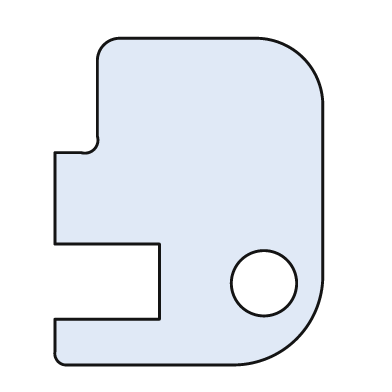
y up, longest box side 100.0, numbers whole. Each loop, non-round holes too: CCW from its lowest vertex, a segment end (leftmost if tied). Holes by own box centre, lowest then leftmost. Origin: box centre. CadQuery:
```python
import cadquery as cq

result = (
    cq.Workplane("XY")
    .moveTo(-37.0, -50.0)
    .lineTo(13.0, -50.0)
    .threePointArc((33.0, -42.0), (41.0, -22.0))
    .lineTo(41.0, 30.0)
    .threePointArc((35.0, 44.0), (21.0, 50.0))
    .lineTo(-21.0, 50.0)
    .threePointArc((-26.0, 48.0), (-28.0, 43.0))
    .lineTo(-28.0, 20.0)
    .threePointArc((-29.0, 16.0), (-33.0, 15.0))
    .lineTo(-41.0, 15.0)
    .lineTo(-41.0, -13.0)
    .lineTo(-9.0, -13.0)
    .lineTo(-9.0, -36.0)
    .lineTo(-41.0, -36.0)
    .lineTo(-41.0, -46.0)
    .threePointArc((-40.0, -49.0), (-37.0, -50.0))
    .close()
    .moveTo(23.0, -25.0)
    .circle(10.0)
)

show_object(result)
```